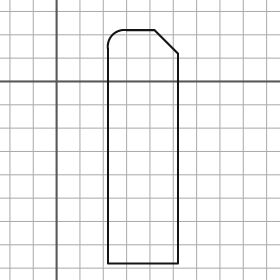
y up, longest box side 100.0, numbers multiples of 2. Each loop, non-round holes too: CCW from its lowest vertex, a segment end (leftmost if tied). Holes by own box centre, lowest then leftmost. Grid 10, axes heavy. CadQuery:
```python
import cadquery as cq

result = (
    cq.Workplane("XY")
    .moveTo(22.0, -78.0)
    .lineTo(52.0, -78.0)
    .lineTo(52.0, 12.0)
    .lineTo(42.0, 22.0)
    .lineTo(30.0, 22.0)
    .threePointArc((24.0, 20.0), (22.0, 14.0))
    .close()
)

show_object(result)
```